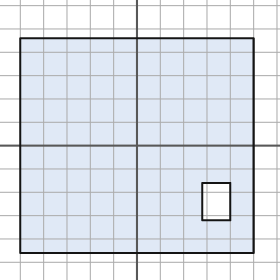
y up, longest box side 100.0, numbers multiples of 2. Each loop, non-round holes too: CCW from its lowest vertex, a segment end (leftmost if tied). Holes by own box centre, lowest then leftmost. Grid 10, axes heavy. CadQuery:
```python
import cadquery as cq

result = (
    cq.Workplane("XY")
    .moveTo(-50.0, -46.0)
    .lineTo(50.0, -46.0)
    .lineTo(50.0, 46.0)
    .lineTo(-50.0, 46.0)
    .close()
    .moveTo(28.0, -32.0)
    .lineTo(40.0, -32.0)
    .lineTo(40.0, -16.0)
    .lineTo(28.0, -16.0)
    .close()
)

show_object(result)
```